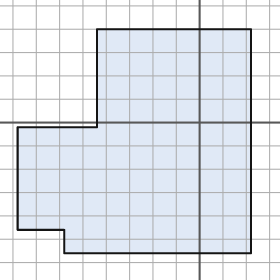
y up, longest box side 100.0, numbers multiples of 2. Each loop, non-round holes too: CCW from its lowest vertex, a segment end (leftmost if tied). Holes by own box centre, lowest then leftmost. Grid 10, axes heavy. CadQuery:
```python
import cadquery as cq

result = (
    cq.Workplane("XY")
    .moveTo(-58.0, -56.0)
    .lineTo(22.0, -56.0)
    .lineTo(22.0, 40.0)
    .lineTo(-44.0, 40.0)
    .lineTo(-44.0, -2.0)
    .lineTo(-78.0, -2.0)
    .lineTo(-78.0, -46.0)
    .lineTo(-58.0, -46.0)
    .close()
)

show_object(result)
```